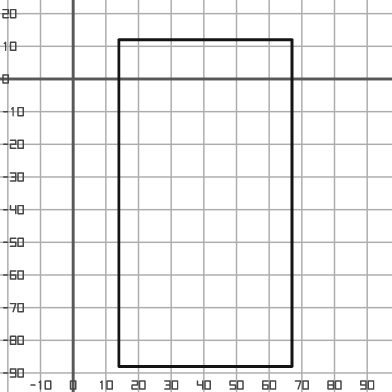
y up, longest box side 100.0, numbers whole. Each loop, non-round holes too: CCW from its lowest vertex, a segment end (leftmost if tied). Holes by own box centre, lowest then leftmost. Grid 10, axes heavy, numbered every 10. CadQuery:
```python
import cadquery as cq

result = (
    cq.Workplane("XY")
    .moveTo(14.0, -88.0)
    .lineTo(67.0, -88.0)
    .lineTo(67.0, 12.0)
    .lineTo(14.0, 12.0)
    .close()
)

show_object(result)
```